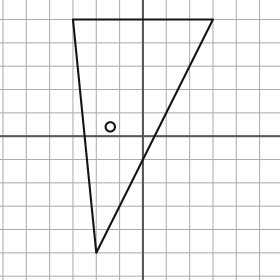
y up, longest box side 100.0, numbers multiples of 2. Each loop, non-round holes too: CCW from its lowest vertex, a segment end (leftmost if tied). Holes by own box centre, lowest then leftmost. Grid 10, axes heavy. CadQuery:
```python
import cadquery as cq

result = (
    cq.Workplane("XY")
    .moveTo(-20.0, -50.0)
    .lineTo(30.0, 50.0)
    .lineTo(-30.0, 50.0)
    .close()
    .moveTo(-14.0, 4.0)
    .circle(2.0)
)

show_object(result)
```